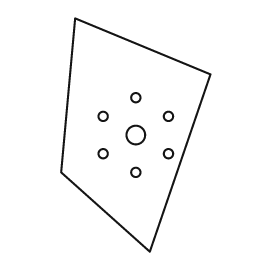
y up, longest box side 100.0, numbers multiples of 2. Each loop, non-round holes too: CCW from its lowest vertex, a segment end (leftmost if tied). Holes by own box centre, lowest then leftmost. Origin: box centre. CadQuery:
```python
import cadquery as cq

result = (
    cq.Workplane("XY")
    .moveTo(6.0, -50.0)
    .lineTo(32.0, 26.0)
    .lineTo(-26.0, 50.0)
    .lineTo(-32.0, -16.0)
    .close()
    .moveTo(0.0, -16.0)
    .circle(2.0)
    .moveTo(-14.0, -8.0)
    .circle(2.0)
    .moveTo(14.0, -8.0)
    .circle(2.0)
    .moveTo(0.0, 0.0)
    .circle(4.0)
    .moveTo(-14.0, 8.0)
    .circle(2.0)
    .moveTo(14.0, 8.0)
    .circle(2.0)
    .moveTo(0.0, 16.0)
    .circle(2.0)
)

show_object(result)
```